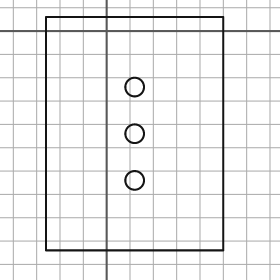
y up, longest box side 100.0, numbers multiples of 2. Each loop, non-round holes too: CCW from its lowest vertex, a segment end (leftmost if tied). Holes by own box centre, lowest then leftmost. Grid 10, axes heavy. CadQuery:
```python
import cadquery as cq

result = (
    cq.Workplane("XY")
    .moveTo(-26.0, -94.0)
    .lineTo(50.0, -94.0)
    .lineTo(50.0, 6.0)
    .lineTo(-26.0, 6.0)
    .close()
    .moveTo(12.0, -64.0)
    .circle(4.0)
    .moveTo(12.0, -44.0)
    .circle(4.0)
    .moveTo(12.0, -24.0)
    .circle(4.0)
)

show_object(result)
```